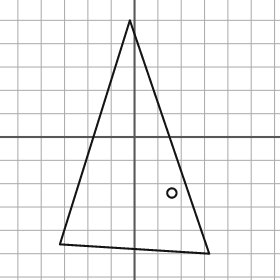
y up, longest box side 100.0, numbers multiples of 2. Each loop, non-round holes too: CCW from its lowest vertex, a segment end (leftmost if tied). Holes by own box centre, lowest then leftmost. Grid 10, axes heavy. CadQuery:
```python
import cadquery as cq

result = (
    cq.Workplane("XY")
    .moveTo(32.0, -50.0)
    .lineTo(-2.0, 50.0)
    .lineTo(-32.0, -46.0)
    .close()
    .moveTo(16.0, -24.0)
    .circle(2.0)
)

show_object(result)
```